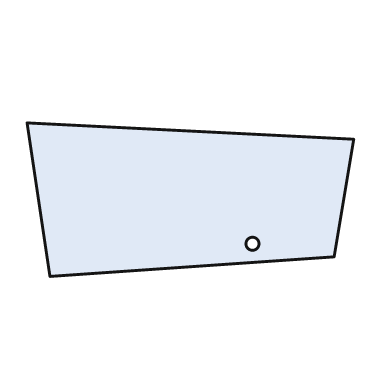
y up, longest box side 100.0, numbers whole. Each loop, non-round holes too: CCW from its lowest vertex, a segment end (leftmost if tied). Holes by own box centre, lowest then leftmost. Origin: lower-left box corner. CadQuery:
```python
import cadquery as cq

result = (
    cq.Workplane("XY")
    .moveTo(7.0, 0.0)
    .lineTo(94.0, 6.0)
    .lineTo(100.0, 42.0)
    .lineTo(0.0, 47.0)
    .close()
    .moveTo(69.0, 10.0)
    .circle(2.0)
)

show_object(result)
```